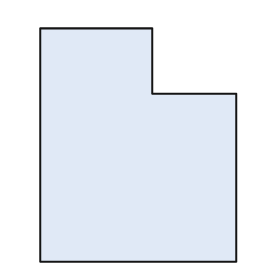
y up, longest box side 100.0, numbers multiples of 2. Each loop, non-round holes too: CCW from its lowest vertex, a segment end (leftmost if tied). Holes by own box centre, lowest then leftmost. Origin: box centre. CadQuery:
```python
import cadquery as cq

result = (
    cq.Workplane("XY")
    .moveTo(-42.0, -50.0)
    .lineTo(42.0, -50.0)
    .lineTo(42.0, 22.0)
    .lineTo(6.0, 22.0)
    .lineTo(6.0, 50.0)
    .lineTo(-42.0, 50.0)
    .close()
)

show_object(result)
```